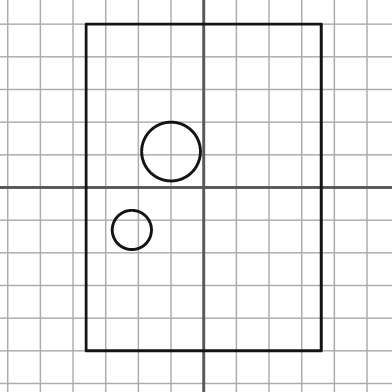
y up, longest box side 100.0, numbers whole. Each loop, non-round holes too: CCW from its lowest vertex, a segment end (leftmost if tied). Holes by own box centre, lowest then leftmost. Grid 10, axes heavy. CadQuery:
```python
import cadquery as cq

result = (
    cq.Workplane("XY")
    .moveTo(-36.0, -50.0)
    .lineTo(36.0, -50.0)
    .lineTo(36.0, 50.0)
    .lineTo(-36.0, 50.0)
    .close()
    .moveTo(-22.0, -13.0)
    .circle(6.0)
    .moveTo(-10.0, 11.0)
    .circle(9.0)
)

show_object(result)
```